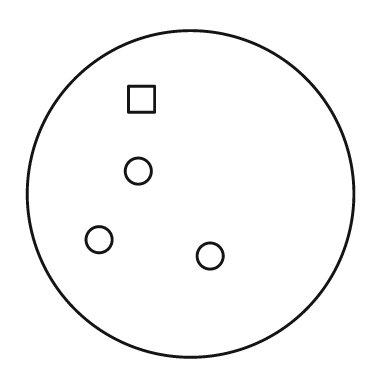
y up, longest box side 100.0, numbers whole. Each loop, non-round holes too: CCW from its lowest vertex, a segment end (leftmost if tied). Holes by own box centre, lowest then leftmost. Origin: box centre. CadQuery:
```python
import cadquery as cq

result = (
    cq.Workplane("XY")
    .moveTo(0.0, 0.0)
    .circle(50.0)
    .moveTo(6.0, -19.0)
    .circle(4.0)
    .moveTo(-28.0, -14.0)
    .circle(4.0)
    .moveTo(-16.0, 7.0)
    .circle(4.0)
    .moveTo(-19.0, 25.0)
    .lineTo(-11.0, 25.0)
    .lineTo(-11.0, 33.0)
    .lineTo(-19.0, 33.0)
    .close()
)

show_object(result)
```